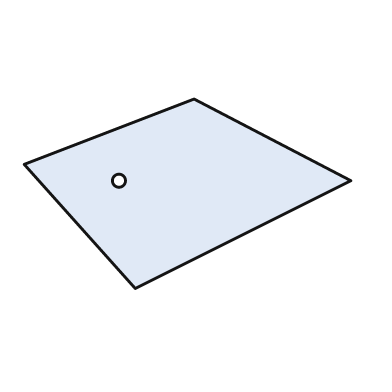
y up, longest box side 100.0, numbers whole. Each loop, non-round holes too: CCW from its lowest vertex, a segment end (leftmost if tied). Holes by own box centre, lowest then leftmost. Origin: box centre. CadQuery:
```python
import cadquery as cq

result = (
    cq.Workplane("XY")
    .moveTo(-16.0, -29.0)
    .lineTo(50.0, 4.0)
    .lineTo(2.0, 29.0)
    .lineTo(-50.0, 9.0)
    .close()
    .moveTo(-21.0, 4.0)
    .circle(2.0)
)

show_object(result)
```